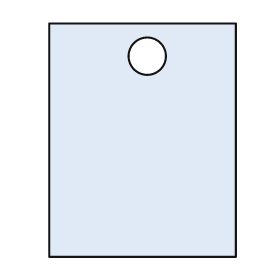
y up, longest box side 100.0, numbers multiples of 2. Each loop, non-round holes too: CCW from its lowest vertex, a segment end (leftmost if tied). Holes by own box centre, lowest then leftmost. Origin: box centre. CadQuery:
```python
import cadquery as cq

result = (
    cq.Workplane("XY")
    .moveTo(-40.0, -50.0)
    .lineTo(40.0, -50.0)
    .lineTo(40.0, 50.0)
    .lineTo(-40.0, 50.0)
    .close()
    .moveTo(2.0, 36.0)
    .circle(8.0)
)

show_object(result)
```